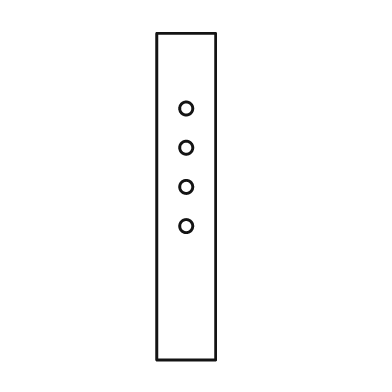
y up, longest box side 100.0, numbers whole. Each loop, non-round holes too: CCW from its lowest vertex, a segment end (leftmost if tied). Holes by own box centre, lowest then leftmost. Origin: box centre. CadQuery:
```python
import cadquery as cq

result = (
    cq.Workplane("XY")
    .moveTo(-9.0, -50.0)
    .lineTo(9.0, -50.0)
    .lineTo(9.0, 50.0)
    .lineTo(-9.0, 50.0)
    .close()
    .moveTo(0.0, -9.0)
    .circle(2.0)
    .moveTo(0.0, 3.0)
    .circle(2.0)
    .moveTo(0.0, 15.0)
    .circle(2.0)
    .moveTo(0.0, 27.0)
    .circle(2.0)
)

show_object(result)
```